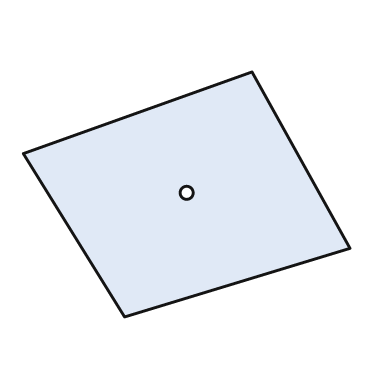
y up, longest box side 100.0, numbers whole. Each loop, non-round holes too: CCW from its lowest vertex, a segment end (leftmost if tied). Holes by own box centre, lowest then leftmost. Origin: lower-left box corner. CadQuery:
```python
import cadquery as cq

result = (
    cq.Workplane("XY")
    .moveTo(31.0, 0.0)
    .lineTo(100.0, 21.0)
    .lineTo(70.0, 75.0)
    .lineTo(0.0, 50.0)
    .close()
    .moveTo(50.0, 38.0)
    .circle(2.0)
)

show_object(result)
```